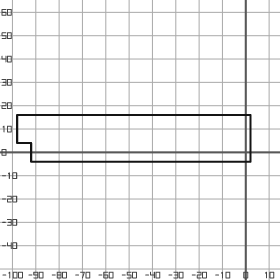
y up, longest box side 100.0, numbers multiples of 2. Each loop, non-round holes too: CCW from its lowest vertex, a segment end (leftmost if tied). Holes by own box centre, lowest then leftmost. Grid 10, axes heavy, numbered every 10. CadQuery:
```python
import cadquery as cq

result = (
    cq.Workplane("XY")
    .moveTo(-92.0, -4.0)
    .lineTo(2.0, -4.0)
    .lineTo(2.0, 16.0)
    .lineTo(-98.0, 16.0)
    .lineTo(-98.0, 4.0)
    .lineTo(-92.0, 4.0)
    .close()
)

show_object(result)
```